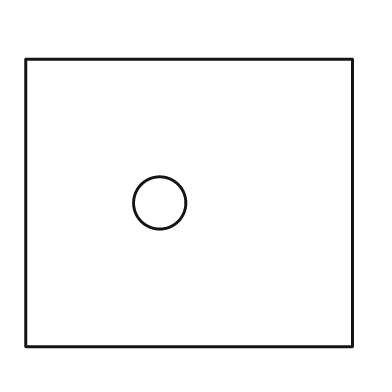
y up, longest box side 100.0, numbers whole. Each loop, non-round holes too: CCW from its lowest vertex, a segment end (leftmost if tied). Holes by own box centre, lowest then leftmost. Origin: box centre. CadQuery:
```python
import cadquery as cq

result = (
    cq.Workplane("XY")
    .moveTo(-50.0, -44.0)
    .lineTo(50.0, -44.0)
    .lineTo(50.0, 44.0)
    .lineTo(-50.0, 44.0)
    .close()
    .moveTo(-9.0, 0.0)
    .circle(8.0)
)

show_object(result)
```